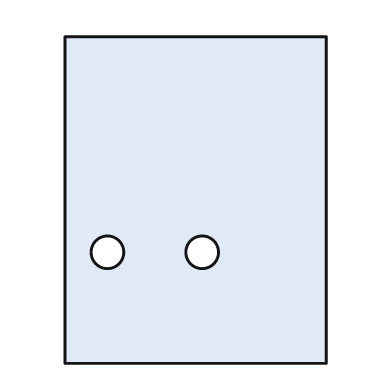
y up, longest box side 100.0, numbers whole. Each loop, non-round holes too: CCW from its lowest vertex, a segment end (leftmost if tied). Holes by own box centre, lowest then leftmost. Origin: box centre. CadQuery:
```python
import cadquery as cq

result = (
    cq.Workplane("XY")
    .moveTo(-40.0, -50.0)
    .lineTo(40.0, -50.0)
    .lineTo(40.0, 50.0)
    .lineTo(-40.0, 50.0)
    .close()
    .moveTo(-27.0, -16.0)
    .circle(5.0)
    .moveTo(2.0, -16.0)
    .circle(5.0)
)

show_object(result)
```